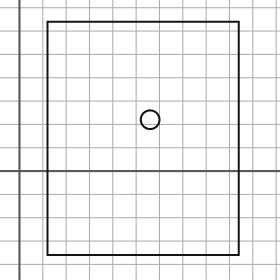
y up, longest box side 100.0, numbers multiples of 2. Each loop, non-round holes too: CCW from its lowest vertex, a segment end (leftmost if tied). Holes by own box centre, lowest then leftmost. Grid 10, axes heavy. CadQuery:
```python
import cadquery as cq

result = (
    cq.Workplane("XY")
    .moveTo(12.0, -36.0)
    .lineTo(94.0, -36.0)
    .lineTo(94.0, 64.0)
    .lineTo(12.0, 64.0)
    .close()
    .moveTo(56.0, 22.0)
    .circle(4.0)
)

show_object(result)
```